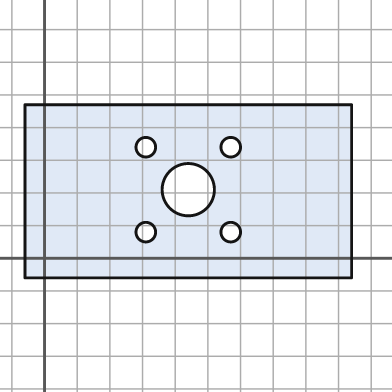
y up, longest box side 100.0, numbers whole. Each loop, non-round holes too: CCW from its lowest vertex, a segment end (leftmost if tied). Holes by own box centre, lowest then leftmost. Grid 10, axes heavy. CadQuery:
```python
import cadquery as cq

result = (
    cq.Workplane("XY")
    .moveTo(-6.0, -6.0)
    .lineTo(94.0, -6.0)
    .lineTo(94.0, 47.0)
    .lineTo(-6.0, 47.0)
    .close()
    .moveTo(31.0, 8.0)
    .circle(3.0)
    .moveTo(57.0, 8.0)
    .circle(3.0)
    .moveTo(44.0, 21.0)
    .circle(8.0)
    .moveTo(31.0, 34.0)
    .circle(3.0)
    .moveTo(57.0, 34.0)
    .circle(3.0)
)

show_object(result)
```